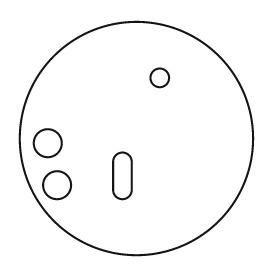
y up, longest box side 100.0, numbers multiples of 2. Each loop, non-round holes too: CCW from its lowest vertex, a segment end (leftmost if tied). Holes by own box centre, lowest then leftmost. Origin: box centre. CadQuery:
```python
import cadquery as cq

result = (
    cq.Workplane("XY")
    .moveTo(0.0, 0.0)
    .circle(50.0)
    .moveTo(-34.0, -20.0)
    .circle(6.0)
    .moveTo(-10.0, -22.0)
    .threePointArc((-6.0, -26.0), (-2.0, -22.0))
    .lineTo(-2.0, -10.0)
    .threePointArc((-6.0, -6.0), (-10.0, -10.0))
    .close()
    .moveTo(-38.0, -2.0)
    .circle(6.0)
    .moveTo(10.0, 26.0)
    .circle(4.0)
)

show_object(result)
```